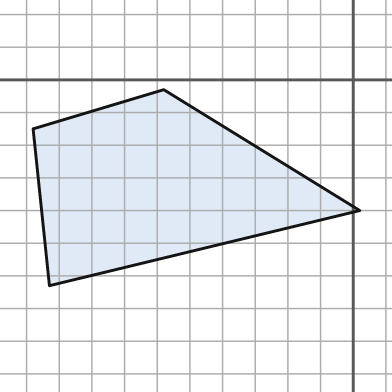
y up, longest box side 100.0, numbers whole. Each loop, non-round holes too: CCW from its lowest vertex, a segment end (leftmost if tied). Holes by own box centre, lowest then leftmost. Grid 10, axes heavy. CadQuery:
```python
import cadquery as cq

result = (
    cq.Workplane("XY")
    .moveTo(-93.0, -63.0)
    .lineTo(2.0, -40.0)
    .lineTo(-58.0, -3.0)
    .lineTo(-98.0, -15.0)
    .close()
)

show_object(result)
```